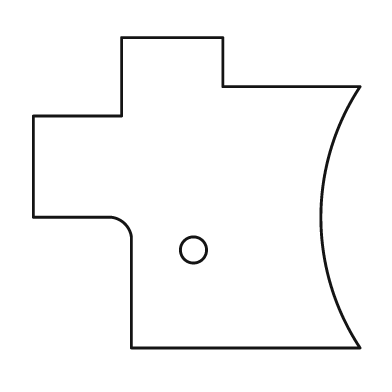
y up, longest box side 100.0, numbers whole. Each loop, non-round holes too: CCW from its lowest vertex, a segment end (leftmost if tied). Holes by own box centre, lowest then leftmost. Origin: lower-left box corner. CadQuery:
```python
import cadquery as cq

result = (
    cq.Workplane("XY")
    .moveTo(30.0, 0.0)
    .lineTo(100.0, 0.0)
    .threePointArc((88.0, 40.0), (100.0, 80.0))
    .lineTo(58.0, 80.0)
    .lineTo(58.0, 95.0)
    .lineTo(27.0, 95.0)
    .lineTo(27.0, 71.0)
    .lineTo(0.0, 71.0)
    .lineTo(0.0, 40.0)
    .lineTo(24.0, 40.0)
    .threePointArc((28.0, 38.0), (30.0, 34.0))
    .close()
    .moveTo(49.0, 30.0)
    .circle(4.0)
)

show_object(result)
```